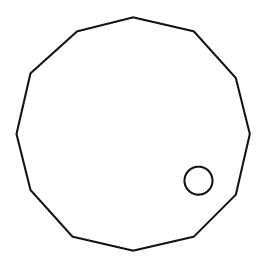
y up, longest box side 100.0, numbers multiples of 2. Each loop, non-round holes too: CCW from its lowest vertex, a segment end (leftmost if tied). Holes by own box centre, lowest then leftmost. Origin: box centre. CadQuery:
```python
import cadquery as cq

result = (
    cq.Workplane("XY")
    .moveTo(0.0, -50.0)
    .lineTo(26.0, -44.0)
    .lineTo(44.0, -26.0)
    .lineTo(50.0, 0.0)
    .lineTo(44.0, 24.0)
    .lineTo(26.0, 44.0)
    .lineTo(0.0, 50.0)
    .lineTo(-24.0, 44.0)
    .lineTo(-44.0, 26.0)
    .lineTo(-50.0, 0.0)
    .lineTo(-44.0, -24.0)
    .lineTo(-26.0, -44.0)
    .close()
    .moveTo(28.0, -20.0)
    .circle(6.0)
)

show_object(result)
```